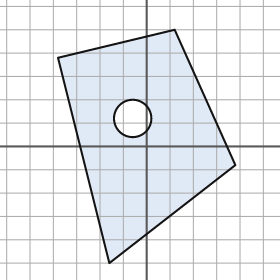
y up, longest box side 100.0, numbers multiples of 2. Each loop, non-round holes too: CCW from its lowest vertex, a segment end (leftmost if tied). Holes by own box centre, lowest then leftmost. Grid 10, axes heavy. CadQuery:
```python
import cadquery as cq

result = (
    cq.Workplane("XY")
    .moveTo(-16.0, -50.0)
    .lineTo(38.0, -8.0)
    .lineTo(12.0, 50.0)
    .lineTo(-38.0, 38.0)
    .close()
    .moveTo(-6.0, 12.0)
    .circle(8.0)
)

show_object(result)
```